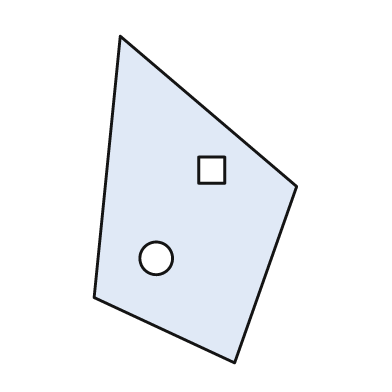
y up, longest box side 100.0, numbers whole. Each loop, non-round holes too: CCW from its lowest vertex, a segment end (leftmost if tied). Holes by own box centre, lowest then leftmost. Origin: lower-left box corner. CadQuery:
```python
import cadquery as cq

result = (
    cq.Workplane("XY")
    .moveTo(43.0, 0.0)
    .lineTo(62.0, 54.0)
    .lineTo(8.0, 100.0)
    .lineTo(0.0, 20.0)
    .close()
    .moveTo(19.0, 32.0)
    .circle(5.0)
    .moveTo(32.0, 55.0)
    .lineTo(40.0, 55.0)
    .lineTo(40.0, 63.0)
    .lineTo(32.0, 63.0)
    .close()
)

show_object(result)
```